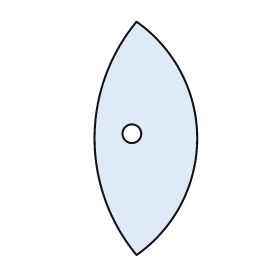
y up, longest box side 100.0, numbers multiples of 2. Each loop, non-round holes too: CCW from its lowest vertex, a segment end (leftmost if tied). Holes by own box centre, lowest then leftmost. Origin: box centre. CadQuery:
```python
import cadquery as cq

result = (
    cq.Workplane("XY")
    .moveTo(-4.0, -50.0)
    .threePointArc((22.0, 0.0), (-4.0, 50.0))
    .threePointArc((-22.0, 0.0), (-4.0, -50.0))
    .close()
    .moveTo(-6.0, 2.0)
    .circle(4.0)
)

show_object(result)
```